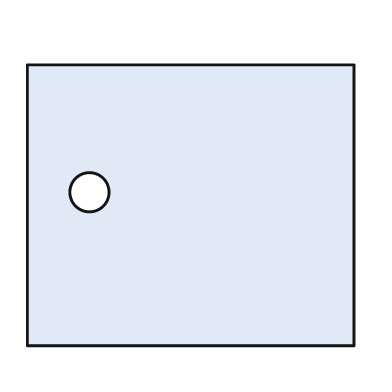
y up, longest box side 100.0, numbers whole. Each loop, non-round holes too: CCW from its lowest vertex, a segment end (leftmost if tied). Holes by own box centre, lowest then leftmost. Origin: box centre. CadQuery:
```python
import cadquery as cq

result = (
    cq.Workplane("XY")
    .moveTo(-50.0, -43.0)
    .lineTo(50.0, -43.0)
    .lineTo(50.0, 43.0)
    .lineTo(-50.0, 43.0)
    .close()
    .moveTo(-31.0, 4.0)
    .circle(6.0)
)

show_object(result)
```